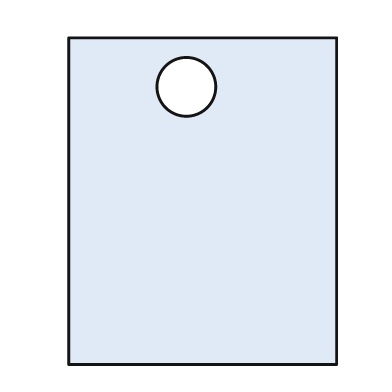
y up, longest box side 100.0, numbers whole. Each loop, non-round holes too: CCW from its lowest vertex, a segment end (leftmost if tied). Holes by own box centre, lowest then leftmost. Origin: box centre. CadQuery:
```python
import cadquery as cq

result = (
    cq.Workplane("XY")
    .moveTo(-41.0, -50.0)
    .lineTo(41.0, -50.0)
    .lineTo(41.0, 50.0)
    .lineTo(-41.0, 50.0)
    .close()
    .moveTo(-5.0, 35.0)
    .circle(9.0)
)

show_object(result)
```